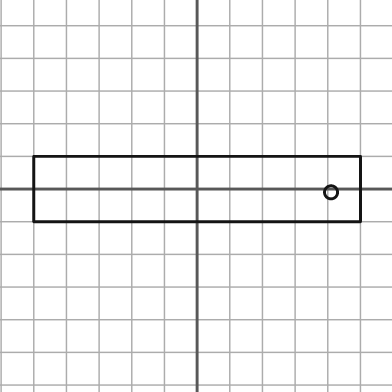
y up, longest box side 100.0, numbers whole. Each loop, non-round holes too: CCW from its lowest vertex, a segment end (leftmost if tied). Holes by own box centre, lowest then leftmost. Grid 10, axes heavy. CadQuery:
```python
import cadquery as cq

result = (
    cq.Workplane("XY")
    .moveTo(-50.0, -10.0)
    .lineTo(50.0, -10.0)
    .lineTo(50.0, 10.0)
    .lineTo(-50.0, 10.0)
    .close()
    .moveTo(41.0, -1.0)
    .circle(2.0)
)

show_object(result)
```